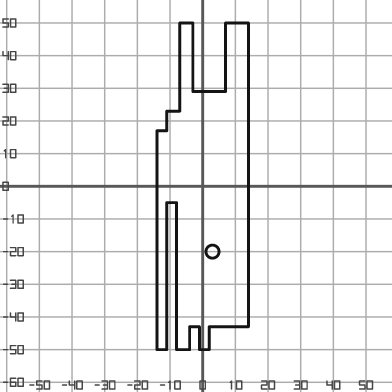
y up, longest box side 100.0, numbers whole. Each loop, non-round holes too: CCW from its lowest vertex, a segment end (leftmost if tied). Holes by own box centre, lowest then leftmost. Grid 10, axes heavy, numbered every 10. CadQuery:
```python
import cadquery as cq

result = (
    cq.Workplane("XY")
    .moveTo(-14.0, -50.0)
    .lineTo(-11.0, -50.0)
    .lineTo(-11.0, -5.0)
    .lineTo(-8.0, -5.0)
    .lineTo(-8.0, -50.0)
    .lineTo(-4.0, -50.0)
    .lineTo(-4.0, -43.0)
    .lineTo(-1.0, -43.0)
    .lineTo(-1.0, -50.0)
    .lineTo(2.0, -50.0)
    .lineTo(2.0, -43.0)
    .lineTo(14.0, -43.0)
    .lineTo(14.0, 50.0)
    .lineTo(7.0, 50.0)
    .lineTo(7.0, 29.0)
    .lineTo(-3.0, 29.0)
    .lineTo(-3.0, 50.0)
    .lineTo(-7.0, 50.0)
    .lineTo(-7.0, 23.0)
    .lineTo(-11.0, 23.0)
    .lineTo(-11.0, 17.0)
    .lineTo(-14.0, 17.0)
    .close()
    .moveTo(3.0, -20.0)
    .circle(2.0)
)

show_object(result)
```